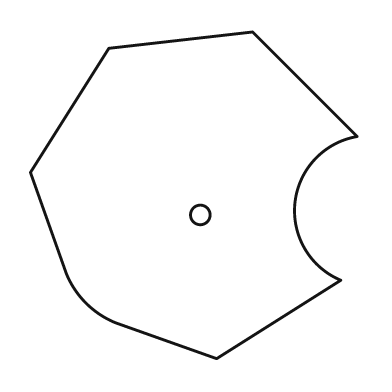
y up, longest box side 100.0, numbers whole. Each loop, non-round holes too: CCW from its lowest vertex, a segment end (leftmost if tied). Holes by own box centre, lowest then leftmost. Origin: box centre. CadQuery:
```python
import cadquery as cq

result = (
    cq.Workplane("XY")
    .moveTo(7.0, -50.0)
    .lineTo(45.0, -26.0)
    .threePointArc((31.0, -2.0), (50.0, 18.0))
    .lineTo(18.0, 50.0)
    .lineTo(-26.0, 45.0)
    .lineTo(-50.0, 7.0)
    .lineTo(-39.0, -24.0)
    .threePointArc((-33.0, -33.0), (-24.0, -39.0))
    .close()
    .moveTo(2.0, -6.0)
    .circle(3.0)
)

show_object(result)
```